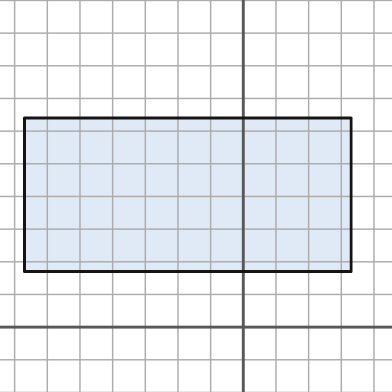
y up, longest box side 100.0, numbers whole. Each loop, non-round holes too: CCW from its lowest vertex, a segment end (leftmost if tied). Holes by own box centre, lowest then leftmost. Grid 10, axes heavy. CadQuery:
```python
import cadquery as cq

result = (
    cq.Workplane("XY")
    .moveTo(-67.0, 17.0)
    .lineTo(33.0, 17.0)
    .lineTo(33.0, 64.0)
    .lineTo(-67.0, 64.0)
    .close()
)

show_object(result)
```